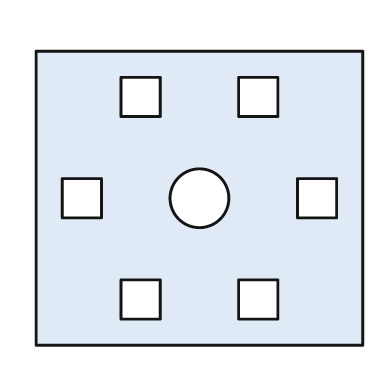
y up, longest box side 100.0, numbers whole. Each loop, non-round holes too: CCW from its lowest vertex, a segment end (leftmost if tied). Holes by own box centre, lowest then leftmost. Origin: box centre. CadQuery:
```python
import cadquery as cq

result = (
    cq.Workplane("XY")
    .moveTo(-50.0, -45.0)
    .lineTo(50.0, -45.0)
    .lineTo(50.0, 45.0)
    .lineTo(-50.0, 45.0)
    .close()
    .moveTo(-24.0, -37.0)
    .lineTo(-12.0, -37.0)
    .lineTo(-12.0, -25.0)
    .lineTo(-24.0, -25.0)
    .close()
    .moveTo(12.0, -37.0)
    .lineTo(24.0, -37.0)
    .lineTo(24.0, -25.0)
    .lineTo(12.0, -25.0)
    .close()
    .moveTo(-42.0, -6.0)
    .lineTo(-30.0, -6.0)
    .lineTo(-30.0, 6.0)
    .lineTo(-42.0, 6.0)
    .close()
    .moveTo(0.0, 0.0)
    .circle(9.0)
    .moveTo(30.0, -6.0)
    .lineTo(42.0, -6.0)
    .lineTo(42.0, 6.0)
    .lineTo(30.0, 6.0)
    .close()
    .moveTo(-24.0, 25.0)
    .lineTo(-12.0, 25.0)
    .lineTo(-12.0, 37.0)
    .lineTo(-24.0, 37.0)
    .close()
    .moveTo(12.0, 25.0)
    .lineTo(24.0, 25.0)
    .lineTo(24.0, 37.0)
    .lineTo(12.0, 37.0)
    .close()
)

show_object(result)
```